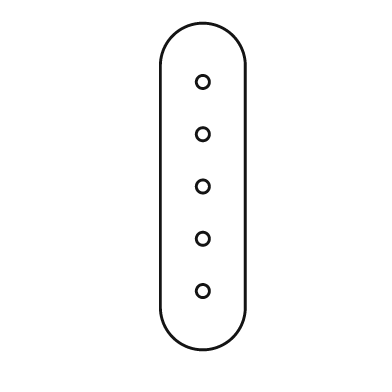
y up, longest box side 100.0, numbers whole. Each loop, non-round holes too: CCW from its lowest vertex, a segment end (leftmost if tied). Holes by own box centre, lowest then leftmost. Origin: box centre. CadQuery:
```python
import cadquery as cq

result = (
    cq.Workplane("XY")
    .moveTo(-13.0, -37.0)
    .threePointArc((0.0, -50.0), (13.0, -37.0))
    .lineTo(13.0, 37.0)
    .threePointArc((0.0, 50.0), (-13.0, 37.0))
    .close()
    .moveTo(0.0, -32.0)
    .circle(2.0)
    .moveTo(0.0, -16.0)
    .circle(2.0)
    .moveTo(0.0, 0.0)
    .circle(2.0)
    .moveTo(0.0, 16.0)
    .circle(2.0)
    .moveTo(0.0, 32.0)
    .circle(2.0)
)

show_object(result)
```